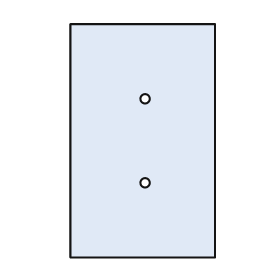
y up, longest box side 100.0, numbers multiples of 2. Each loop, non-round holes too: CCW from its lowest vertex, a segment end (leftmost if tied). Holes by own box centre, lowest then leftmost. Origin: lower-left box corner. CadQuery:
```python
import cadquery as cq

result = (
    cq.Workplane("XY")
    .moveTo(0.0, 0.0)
    .lineTo(62.0, 0.0)
    .lineTo(62.0, 100.0)
    .lineTo(0.0, 100.0)
    .close()
    .moveTo(32.0, 32.0)
    .circle(2.0)
    .moveTo(32.0, 68.0)
    .circle(2.0)
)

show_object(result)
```